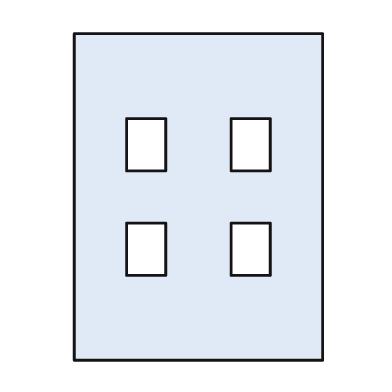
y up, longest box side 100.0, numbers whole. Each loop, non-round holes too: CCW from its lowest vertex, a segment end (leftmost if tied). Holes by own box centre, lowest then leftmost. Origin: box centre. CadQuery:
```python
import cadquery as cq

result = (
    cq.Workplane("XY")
    .moveTo(-38.0, -50.0)
    .lineTo(38.0, -50.0)
    .lineTo(38.0, 50.0)
    .lineTo(-38.0, 50.0)
    .close()
    .moveTo(-22.0, -24.0)
    .lineTo(-10.0, -24.0)
    .lineTo(-10.0, -8.0)
    .lineTo(-22.0, -8.0)
    .close()
    .moveTo(10.0, -24.0)
    .lineTo(22.0, -24.0)
    .lineTo(22.0, -8.0)
    .lineTo(10.0, -8.0)
    .close()
    .moveTo(-22.0, 8.0)
    .lineTo(-10.0, 8.0)
    .lineTo(-10.0, 24.0)
    .lineTo(-22.0, 24.0)
    .close()
    .moveTo(10.0, 8.0)
    .lineTo(22.0, 8.0)
    .lineTo(22.0, 24.0)
    .lineTo(10.0, 24.0)
    .close()
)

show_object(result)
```